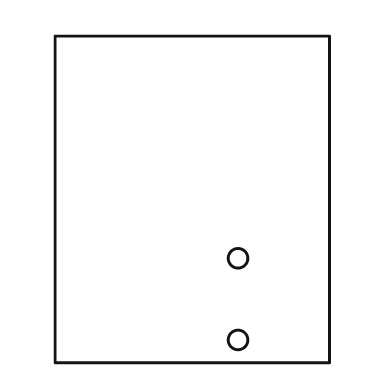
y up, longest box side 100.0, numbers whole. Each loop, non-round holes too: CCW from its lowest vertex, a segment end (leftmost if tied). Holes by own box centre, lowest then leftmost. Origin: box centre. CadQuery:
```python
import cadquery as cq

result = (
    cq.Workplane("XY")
    .moveTo(-42.0, -50.0)
    .lineTo(42.0, -50.0)
    .lineTo(42.0, 50.0)
    .lineTo(-42.0, 50.0)
    .close()
    .moveTo(14.0, -43.0)
    .circle(3.0)
    .moveTo(14.0, -18.0)
    .circle(3.0)
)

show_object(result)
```